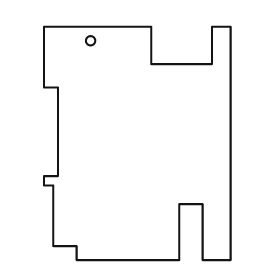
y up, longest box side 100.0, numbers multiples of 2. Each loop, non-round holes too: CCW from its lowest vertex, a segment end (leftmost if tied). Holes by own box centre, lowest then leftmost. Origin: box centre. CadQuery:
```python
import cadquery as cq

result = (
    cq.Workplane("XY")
    .moveTo(-26.0, -50.0)
    .lineTo(18.0, -50.0)
    .lineTo(18.0, -26.0)
    .lineTo(28.0, -26.0)
    .lineTo(28.0, -50.0)
    .lineTo(40.0, -50.0)
    .lineTo(40.0, 50.0)
    .lineTo(32.0, 50.0)
    .lineTo(32.0, 34.0)
    .lineTo(6.0, 34.0)
    .lineTo(6.0, 50.0)
    .lineTo(-40.0, 50.0)
    .lineTo(-40.0, 24.0)
    .lineTo(-34.0, 24.0)
    .lineTo(-34.0, -14.0)
    .lineTo(-40.0, -14.0)
    .lineTo(-40.0, -18.0)
    .lineTo(-36.0, -18.0)
    .lineTo(-36.0, -44.0)
    .lineTo(-26.0, -44.0)
    .close()
    .moveTo(-20.0, 44.0)
    .circle(2.0)
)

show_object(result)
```